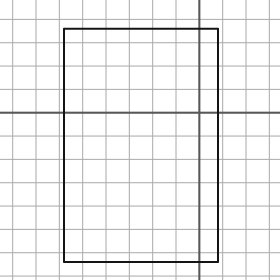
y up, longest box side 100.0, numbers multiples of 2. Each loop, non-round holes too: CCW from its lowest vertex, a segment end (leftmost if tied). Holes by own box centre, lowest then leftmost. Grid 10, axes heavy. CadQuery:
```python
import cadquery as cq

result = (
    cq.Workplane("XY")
    .moveTo(-58.0, -64.0)
    .lineTo(8.0, -64.0)
    .lineTo(8.0, 36.0)
    .lineTo(-58.0, 36.0)
    .close()
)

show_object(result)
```